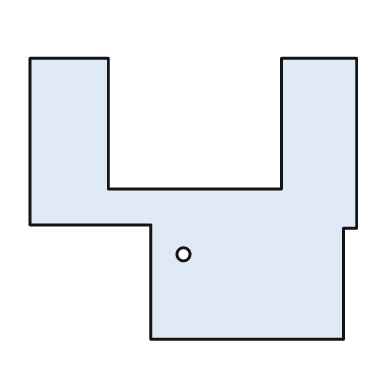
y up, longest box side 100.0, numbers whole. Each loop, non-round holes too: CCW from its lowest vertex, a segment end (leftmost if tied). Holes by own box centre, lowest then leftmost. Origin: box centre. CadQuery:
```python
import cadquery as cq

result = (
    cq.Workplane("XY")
    .moveTo(-13.0, -43.0)
    .lineTo(46.0, -43.0)
    .lineTo(46.0, -9.0)
    .lineTo(50.0, -9.0)
    .lineTo(50.0, 43.0)
    .lineTo(27.0, 43.0)
    .lineTo(27.0, 3.0)
    .lineTo(-26.0, 3.0)
    .lineTo(-26.0, 43.0)
    .lineTo(-50.0, 43.0)
    .lineTo(-50.0, -8.0)
    .lineTo(-13.0, -8.0)
    .close()
    .moveTo(-3.0, -17.0)
    .circle(2.0)
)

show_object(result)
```